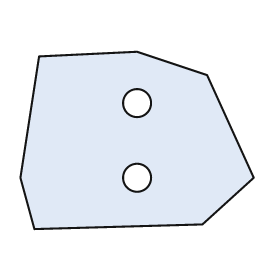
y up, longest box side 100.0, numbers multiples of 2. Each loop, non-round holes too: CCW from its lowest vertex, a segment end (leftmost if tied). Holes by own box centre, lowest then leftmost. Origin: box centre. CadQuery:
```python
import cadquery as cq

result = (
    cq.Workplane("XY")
    .moveTo(-44.0, -38.0)
    .lineTo(28.0, -36.0)
    .lineTo(50.0, -16.0)
    .lineTo(30.0, 28.0)
    .lineTo(0.0, 38.0)
    .lineTo(-42.0, 36.0)
    .lineTo(-50.0, -16.0)
    .close()
    .moveTo(0.0, -16.0)
    .circle(6.0)
    .moveTo(0.0, 16.0)
    .circle(6.0)
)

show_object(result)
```